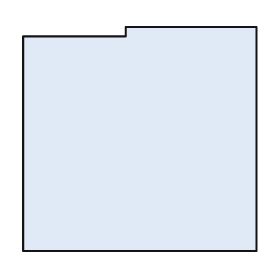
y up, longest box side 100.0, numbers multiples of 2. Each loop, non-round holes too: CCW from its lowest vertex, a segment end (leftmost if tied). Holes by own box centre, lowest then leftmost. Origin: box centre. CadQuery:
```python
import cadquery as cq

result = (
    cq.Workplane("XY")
    .moveTo(-50.0, -48.0)
    .lineTo(50.0, -48.0)
    .lineTo(50.0, 48.0)
    .lineTo(-6.0, 48.0)
    .lineTo(-6.0, 44.0)
    .lineTo(-50.0, 44.0)
    .close()
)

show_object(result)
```